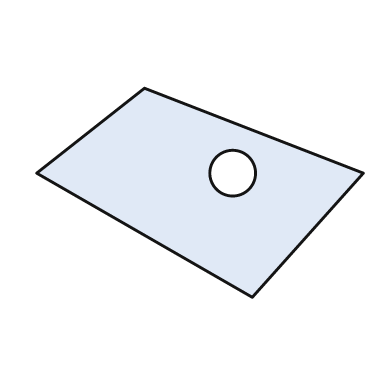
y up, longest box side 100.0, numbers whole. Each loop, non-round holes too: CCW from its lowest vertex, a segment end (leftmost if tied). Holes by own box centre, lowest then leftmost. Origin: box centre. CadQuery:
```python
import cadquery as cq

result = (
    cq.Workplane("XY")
    .moveTo(16.0, -32.0)
    .lineTo(50.0, 6.0)
    .lineTo(-17.0, 32.0)
    .lineTo(-50.0, 6.0)
    .close()
    .moveTo(10.0, 6.0)
    .circle(7.0)
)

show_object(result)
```